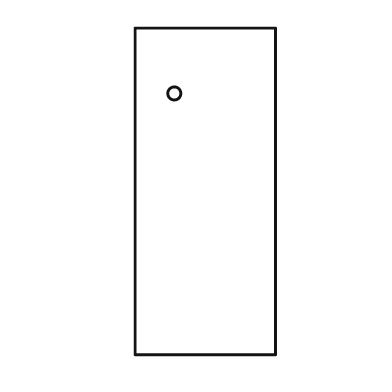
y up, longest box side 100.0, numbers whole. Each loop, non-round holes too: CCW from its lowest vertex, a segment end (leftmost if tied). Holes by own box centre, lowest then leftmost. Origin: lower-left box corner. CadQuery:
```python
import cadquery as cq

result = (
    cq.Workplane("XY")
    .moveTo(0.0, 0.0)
    .lineTo(43.0, 0.0)
    .lineTo(43.0, 100.0)
    .lineTo(0.0, 100.0)
    .close()
    .moveTo(12.0, 80.0)
    .circle(2.0)
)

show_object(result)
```